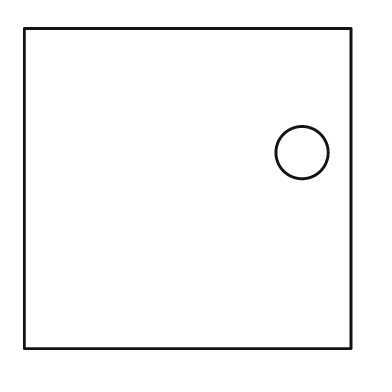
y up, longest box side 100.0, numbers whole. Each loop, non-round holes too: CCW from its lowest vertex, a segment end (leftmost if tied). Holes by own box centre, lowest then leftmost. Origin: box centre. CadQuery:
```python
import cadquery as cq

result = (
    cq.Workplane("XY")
    .moveTo(-50.0, -49.0)
    .lineTo(50.0, -49.0)
    .lineTo(50.0, 49.0)
    .lineTo(-50.0, 49.0)
    .close()
    .moveTo(35.0, 11.0)
    .circle(8.0)
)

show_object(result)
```